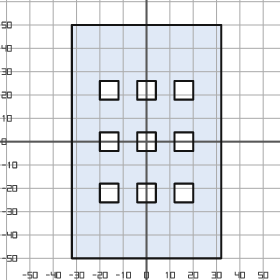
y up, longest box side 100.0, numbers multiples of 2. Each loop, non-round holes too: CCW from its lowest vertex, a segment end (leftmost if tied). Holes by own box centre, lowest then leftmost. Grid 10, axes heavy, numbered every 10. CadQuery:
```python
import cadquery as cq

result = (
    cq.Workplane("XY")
    .moveTo(-32.0, -50.0)
    .lineTo(32.0, -50.0)
    .lineTo(32.0, 50.0)
    .lineTo(-32.0, 50.0)
    .close()
    .moveTo(-20.0, -26.0)
    .lineTo(-12.0, -26.0)
    .lineTo(-12.0, -18.0)
    .lineTo(-20.0, -18.0)
    .close()
    .moveTo(-4.0, -26.0)
    .lineTo(4.0, -26.0)
    .lineTo(4.0, -18.0)
    .lineTo(-4.0, -18.0)
    .close()
    .moveTo(12.0, -26.0)
    .lineTo(20.0, -26.0)
    .lineTo(20.0, -18.0)
    .lineTo(12.0, -18.0)
    .close()
    .moveTo(-20.0, -4.0)
    .lineTo(-12.0, -4.0)
    .lineTo(-12.0, 4.0)
    .lineTo(-20.0, 4.0)
    .close()
    .moveTo(-4.0, -4.0)
    .lineTo(4.0, -4.0)
    .lineTo(4.0, 4.0)
    .lineTo(-4.0, 4.0)
    .close()
    .moveTo(12.0, -4.0)
    .lineTo(20.0, -4.0)
    .lineTo(20.0, 4.0)
    .lineTo(12.0, 4.0)
    .close()
    .moveTo(-20.0, 18.0)
    .lineTo(-12.0, 18.0)
    .lineTo(-12.0, 26.0)
    .lineTo(-20.0, 26.0)
    .close()
    .moveTo(-4.0, 18.0)
    .lineTo(4.0, 18.0)
    .lineTo(4.0, 26.0)
    .lineTo(-4.0, 26.0)
    .close()
    .moveTo(12.0, 18.0)
    .lineTo(20.0, 18.0)
    .lineTo(20.0, 26.0)
    .lineTo(12.0, 26.0)
    .close()
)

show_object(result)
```